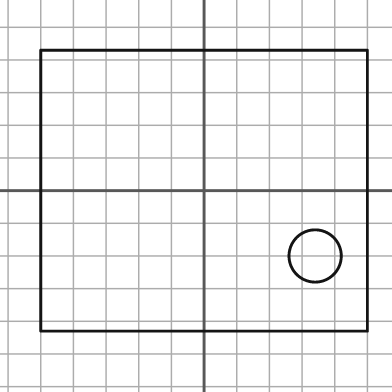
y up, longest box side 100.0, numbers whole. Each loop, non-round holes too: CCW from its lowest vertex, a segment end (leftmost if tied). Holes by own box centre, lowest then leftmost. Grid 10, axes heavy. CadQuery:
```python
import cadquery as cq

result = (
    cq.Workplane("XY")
    .moveTo(-50.0, -43.0)
    .lineTo(50.0, -43.0)
    .lineTo(50.0, 43.0)
    .lineTo(-50.0, 43.0)
    .close()
    .moveTo(34.0, -20.0)
    .circle(8.0)
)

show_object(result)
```